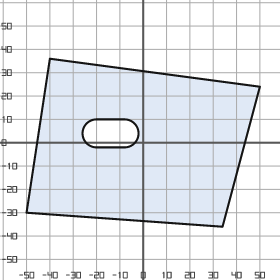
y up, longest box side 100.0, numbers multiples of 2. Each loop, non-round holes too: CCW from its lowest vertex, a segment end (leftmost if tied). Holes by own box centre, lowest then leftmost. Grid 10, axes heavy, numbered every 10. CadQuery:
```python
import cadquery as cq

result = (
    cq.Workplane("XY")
    .moveTo(34.0, -36.0)
    .lineTo(50.0, 24.0)
    .lineTo(-40.0, 36.0)
    .lineTo(-50.0, -30.0)
    .close()
    .moveTo(-20.0, -2.0)
    .lineTo(-8.0, -2.0)
    .threePointArc((-2.0, 4.0), (-8.0, 10.0))
    .lineTo(-20.0, 10.0)
    .threePointArc((-26.0, 4.0), (-20.0, -2.0))
    .close()
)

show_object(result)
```